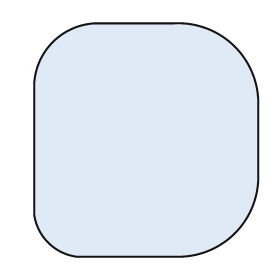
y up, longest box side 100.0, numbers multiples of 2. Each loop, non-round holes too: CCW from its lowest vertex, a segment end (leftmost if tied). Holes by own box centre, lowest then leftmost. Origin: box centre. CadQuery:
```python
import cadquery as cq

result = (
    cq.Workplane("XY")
    .moveTo(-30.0, -50.0)
    .lineTo(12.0, -50.0)
    .threePointArc((38.0, -40.0), (48.0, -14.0))
    .lineTo(48.0, 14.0)
    .threePointArc((38.0, 40.0), (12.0, 50.0))
    .lineTo(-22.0, 50.0)
    .threePointArc((-40.0, 42.0), (-48.0, 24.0))
    .lineTo(-48.0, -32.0)
    .threePointArc((-42.0, -44.0), (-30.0, -50.0))
    .close()
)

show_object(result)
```